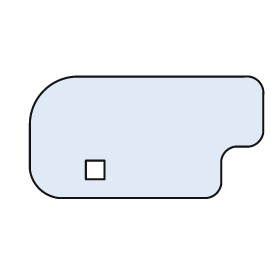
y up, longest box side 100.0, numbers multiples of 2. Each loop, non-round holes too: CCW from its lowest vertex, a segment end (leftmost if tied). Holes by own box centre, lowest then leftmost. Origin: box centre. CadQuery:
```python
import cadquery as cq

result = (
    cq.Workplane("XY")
    .moveTo(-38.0, -26.0)
    .lineTo(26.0, -26.0)
    .threePointArc((30.0, -24.0), (32.0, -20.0))
    .lineTo(32.0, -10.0)
    .threePointArc((34.0, -6.0), (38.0, -4.0))
    .lineTo(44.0, -4.0)
    .threePointArc((48.0, -2.0), (50.0, 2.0))
    .lineTo(50.0, 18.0)
    .threePointArc((48.0, 24.0), (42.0, 26.0))
    .lineTo(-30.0, 26.0)
    .threePointArc((-44.0, 20.0), (-50.0, 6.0))
    .lineTo(-50.0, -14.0)
    .threePointArc((-46.0, -22.0), (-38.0, -26.0))
    .close()
    .moveTo(-26.0, -18.0)
    .lineTo(-18.0, -18.0)
    .lineTo(-18.0, -10.0)
    .lineTo(-26.0, -10.0)
    .close()
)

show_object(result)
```